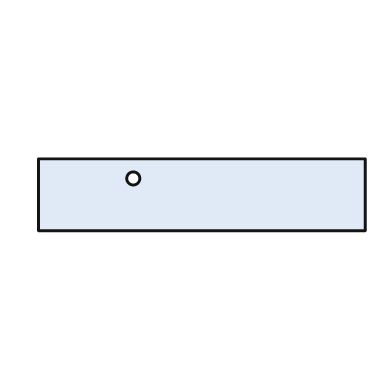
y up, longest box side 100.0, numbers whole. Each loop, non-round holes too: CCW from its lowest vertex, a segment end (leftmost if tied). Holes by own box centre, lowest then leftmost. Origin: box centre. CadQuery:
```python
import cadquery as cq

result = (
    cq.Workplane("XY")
    .moveTo(-50.0, -11.0)
    .lineTo(50.0, -11.0)
    .lineTo(50.0, 11.0)
    .lineTo(-50.0, 11.0)
    .close()
    .moveTo(-21.0, 5.0)
    .circle(2.0)
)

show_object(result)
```